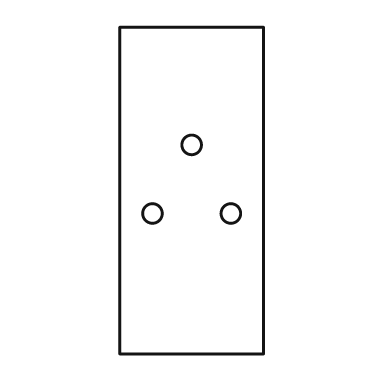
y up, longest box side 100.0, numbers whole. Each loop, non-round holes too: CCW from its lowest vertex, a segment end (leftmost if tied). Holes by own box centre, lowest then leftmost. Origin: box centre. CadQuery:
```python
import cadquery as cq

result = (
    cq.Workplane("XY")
    .moveTo(-22.0, -50.0)
    .lineTo(22.0, -50.0)
    .lineTo(22.0, 50.0)
    .lineTo(-22.0, 50.0)
    .close()
    .moveTo(-12.0, -7.0)
    .circle(3.0)
    .moveTo(12.0, -7.0)
    .circle(3.0)
    .moveTo(0.0, 14.0)
    .circle(3.0)
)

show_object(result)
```